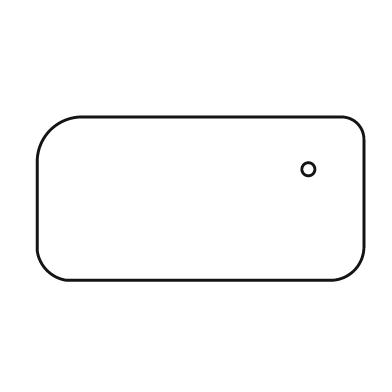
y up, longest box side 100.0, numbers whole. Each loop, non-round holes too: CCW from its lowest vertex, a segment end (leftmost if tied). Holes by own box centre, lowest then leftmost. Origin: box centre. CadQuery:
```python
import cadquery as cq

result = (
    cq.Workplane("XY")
    .moveTo(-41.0, -25.0)
    .lineTo(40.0, -25.0)
    .threePointArc((47.0, -22.0), (50.0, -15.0))
    .lineTo(50.0, 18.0)
    .threePointArc((48.0, 23.0), (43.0, 25.0))
    .lineTo(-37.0, 25.0)
    .threePointArc((-46.0, 21.0), (-50.0, 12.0))
    .lineTo(-50.0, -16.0)
    .threePointArc((-47.0, -22.0), (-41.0, -25.0))
    .close()
    .moveTo(33.0, 9.0)
    .circle(2.0)
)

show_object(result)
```